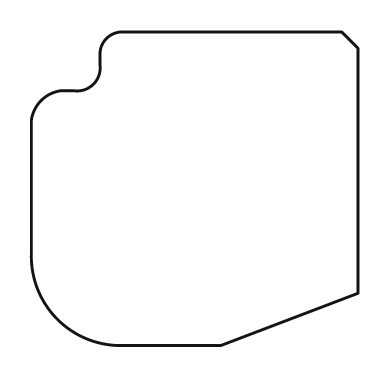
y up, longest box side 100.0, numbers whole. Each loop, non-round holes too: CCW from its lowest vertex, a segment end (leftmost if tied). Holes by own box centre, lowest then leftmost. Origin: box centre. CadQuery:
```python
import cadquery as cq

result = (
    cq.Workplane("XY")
    .moveTo(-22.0, -48.0)
    .lineTo(8.0, -48.0)
    .lineTo(50.0, -32.0)
    .lineTo(50.0, 43.0)
    .lineTo(45.0, 48.0)
    .lineTo(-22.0, 48.0)
    .threePointArc((-27.0, 46.0), (-29.0, 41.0))
    .lineTo(-29.0, 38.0)
    .threePointArc((-31.0, 32.0), (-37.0, 30.0))
    .lineTo(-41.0, 30.0)
    .threePointArc((-47.0, 27.0), (-50.0, 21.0))
    .lineTo(-50.0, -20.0)
    .threePointArc((-42.0, -40.0), (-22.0, -48.0))
    .close()
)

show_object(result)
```